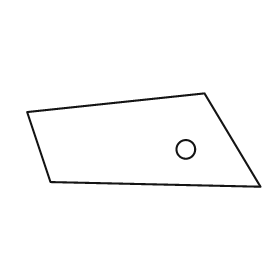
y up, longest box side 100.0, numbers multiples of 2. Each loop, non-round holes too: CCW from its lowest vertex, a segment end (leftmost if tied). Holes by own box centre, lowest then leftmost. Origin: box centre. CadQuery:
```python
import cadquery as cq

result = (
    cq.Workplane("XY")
    .moveTo(50.0, -20.0)
    .lineTo(26.0, 20.0)
    .lineTo(-50.0, 12.0)
    .lineTo(-40.0, -18.0)
    .close()
    .moveTo(18.0, -4.0)
    .circle(4.0)
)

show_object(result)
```